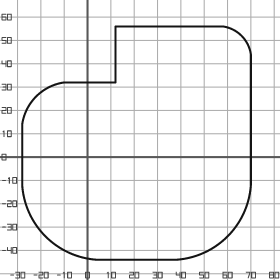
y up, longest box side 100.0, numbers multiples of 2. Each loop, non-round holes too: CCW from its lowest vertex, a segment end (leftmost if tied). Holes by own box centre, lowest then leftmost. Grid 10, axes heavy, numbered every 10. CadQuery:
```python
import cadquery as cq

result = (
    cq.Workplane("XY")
    .moveTo(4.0, -44.0)
    .lineTo(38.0, -44.0)
    .threePointArc((60.0, -34.0), (70.0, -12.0))
    .lineTo(70.0, 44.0)
    .threePointArc((66.0, 52.0), (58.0, 56.0))
    .lineTo(12.0, 56.0)
    .lineTo(12.0, 32.0)
    .lineTo(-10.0, 32.0)
    .threePointArc((-22.0, 26.0), (-28.0, 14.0))
    .lineTo(-28.0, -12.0)
    .threePointArc((-18.0, -34.0), (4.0, -44.0))
    .close()
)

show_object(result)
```